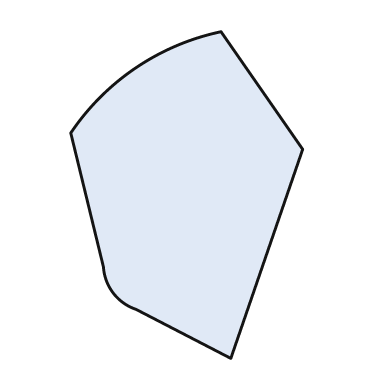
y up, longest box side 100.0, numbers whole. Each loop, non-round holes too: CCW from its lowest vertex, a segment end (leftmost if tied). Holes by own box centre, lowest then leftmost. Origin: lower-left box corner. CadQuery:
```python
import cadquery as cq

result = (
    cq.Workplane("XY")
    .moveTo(49.0, 0.0)
    .lineTo(71.0, 64.0)
    .lineTo(46.0, 100.0)
    .threePointArc((20.0, 89.0), (0.0, 69.0))
    .lineTo(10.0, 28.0)
    .threePointArc((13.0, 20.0), (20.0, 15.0))
    .close()
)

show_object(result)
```